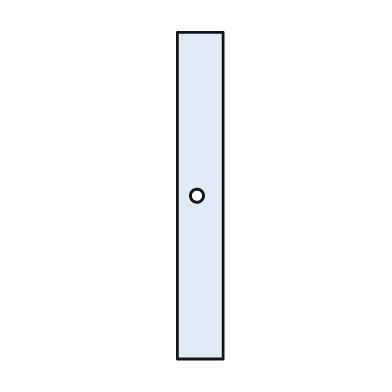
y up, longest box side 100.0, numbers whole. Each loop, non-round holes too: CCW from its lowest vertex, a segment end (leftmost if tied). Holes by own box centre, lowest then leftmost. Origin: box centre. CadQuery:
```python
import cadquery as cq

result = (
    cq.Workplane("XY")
    .moveTo(-7.0, -50.0)
    .lineTo(7.0, -50.0)
    .lineTo(7.0, 50.0)
    .lineTo(-7.0, 50.0)
    .close()
    .moveTo(-1.0, 0.0)
    .circle(2.0)
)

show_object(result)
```